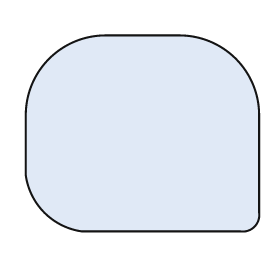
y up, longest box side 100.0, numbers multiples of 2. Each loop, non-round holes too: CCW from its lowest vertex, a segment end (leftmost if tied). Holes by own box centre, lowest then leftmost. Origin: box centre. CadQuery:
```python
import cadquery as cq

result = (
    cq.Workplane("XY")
    .moveTo(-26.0, -42.0)
    .lineTo(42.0, -42.0)
    .threePointArc((48.0, -40.0), (50.0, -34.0))
    .lineTo(50.0, 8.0)
    .threePointArc((40.0, 32.0), (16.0, 42.0))
    .lineTo(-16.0, 42.0)
    .threePointArc((-40.0, 32.0), (-50.0, 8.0))
    .lineTo(-50.0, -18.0)
    .threePointArc((-42.0, -34.0), (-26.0, -42.0))
    .close()
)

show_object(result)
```